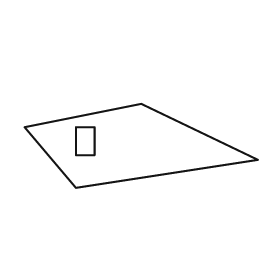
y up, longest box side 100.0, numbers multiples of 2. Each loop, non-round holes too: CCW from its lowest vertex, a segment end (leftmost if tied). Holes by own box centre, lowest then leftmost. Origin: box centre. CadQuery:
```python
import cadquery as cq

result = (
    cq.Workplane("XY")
    .moveTo(-28.0, -18.0)
    .lineTo(50.0, -6.0)
    .lineTo(0.0, 18.0)
    .lineTo(-50.0, 8.0)
    .close()
    .moveTo(-28.0, -4.0)
    .lineTo(-20.0, -4.0)
    .lineTo(-20.0, 8.0)
    .lineTo(-28.0, 8.0)
    .close()
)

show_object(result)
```